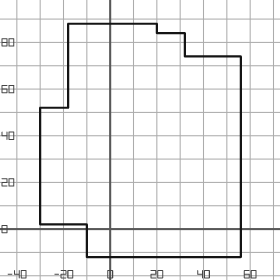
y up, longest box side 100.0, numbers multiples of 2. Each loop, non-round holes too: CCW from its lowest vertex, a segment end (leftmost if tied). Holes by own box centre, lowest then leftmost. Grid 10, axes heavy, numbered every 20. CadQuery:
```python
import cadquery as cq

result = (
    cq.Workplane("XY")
    .moveTo(-10.0, -12.0)
    .lineTo(56.0, -12.0)
    .lineTo(56.0, 74.0)
    .lineTo(32.0, 74.0)
    .lineTo(32.0, 84.0)
    .lineTo(20.0, 84.0)
    .lineTo(20.0, 88.0)
    .lineTo(-18.0, 88.0)
    .lineTo(-18.0, 52.0)
    .lineTo(-30.0, 52.0)
    .lineTo(-30.0, 2.0)
    .lineTo(-10.0, 2.0)
    .close()
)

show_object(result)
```